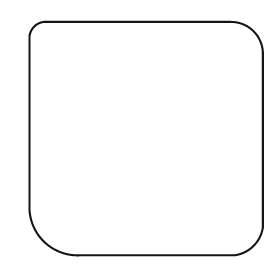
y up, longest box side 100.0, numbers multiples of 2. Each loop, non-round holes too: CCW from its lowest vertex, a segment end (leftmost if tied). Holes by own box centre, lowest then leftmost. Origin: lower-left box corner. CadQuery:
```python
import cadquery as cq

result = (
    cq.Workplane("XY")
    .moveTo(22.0, 0.0)
    .lineTo(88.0, 0.0)
    .threePointArc((96.0, 4.0), (100.0, 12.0))
    .lineTo(100.0, 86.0)
    .threePointArc((96.0, 96.0), (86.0, 100.0))
    .lineTo(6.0, 100.0)
    .threePointArc((2.0, 98.0), (0.0, 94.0))
    .lineTo(0.0, 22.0)
    .threePointArc((6.0, 6.0), (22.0, 0.0))
    .close()
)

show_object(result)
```